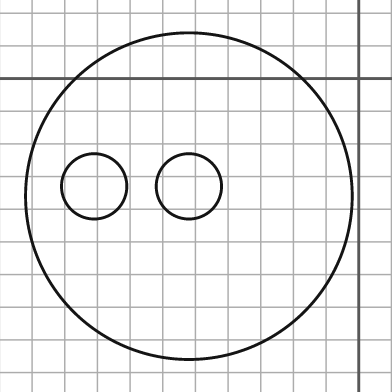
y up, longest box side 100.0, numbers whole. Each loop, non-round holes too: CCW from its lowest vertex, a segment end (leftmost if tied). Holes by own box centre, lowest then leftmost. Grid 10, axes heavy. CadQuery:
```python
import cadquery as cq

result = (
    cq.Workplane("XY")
    .moveTo(-52.0, -36.0)
    .circle(50.0)
    .moveTo(-81.0, -33.0)
    .circle(10.0)
    .moveTo(-52.0, -33.0)
    .circle(10.0)
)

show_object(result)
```